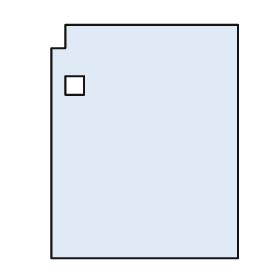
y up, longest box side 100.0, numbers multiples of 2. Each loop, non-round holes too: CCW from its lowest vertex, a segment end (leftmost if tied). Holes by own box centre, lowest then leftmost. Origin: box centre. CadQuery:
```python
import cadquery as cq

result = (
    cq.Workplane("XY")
    .moveTo(-40.0, -50.0)
    .lineTo(40.0, -50.0)
    .lineTo(40.0, 50.0)
    .lineTo(-34.0, 50.0)
    .lineTo(-34.0, 40.0)
    .lineTo(-40.0, 40.0)
    .close()
    .moveTo(-34.0, 20.0)
    .lineTo(-26.0, 20.0)
    .lineTo(-26.0, 28.0)
    .lineTo(-34.0, 28.0)
    .close()
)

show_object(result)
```